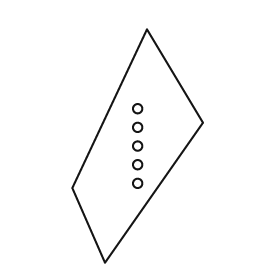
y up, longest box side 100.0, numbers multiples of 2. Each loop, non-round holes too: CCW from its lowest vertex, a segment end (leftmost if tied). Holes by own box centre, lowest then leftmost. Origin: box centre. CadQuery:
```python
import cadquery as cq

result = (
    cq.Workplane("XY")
    .moveTo(-14.0, -50.0)
    .lineTo(28.0, 10.0)
    .lineTo(4.0, 50.0)
    .lineTo(-28.0, -18.0)
    .close()
    .moveTo(0.0, -16.0)
    .circle(2.0)
    .moveTo(0.0, -8.0)
    .circle(2.0)
    .moveTo(0.0, 0.0)
    .circle(2.0)
    .moveTo(0.0, 8.0)
    .circle(2.0)
    .moveTo(0.0, 16.0)
    .circle(2.0)
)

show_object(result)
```